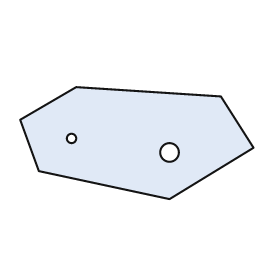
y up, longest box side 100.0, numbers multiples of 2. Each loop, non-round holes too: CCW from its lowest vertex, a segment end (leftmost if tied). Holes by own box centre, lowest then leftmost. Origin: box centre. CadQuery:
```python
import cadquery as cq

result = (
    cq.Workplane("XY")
    .moveTo(14.0, -24.0)
    .lineTo(50.0, -2.0)
    .lineTo(36.0, 20.0)
    .lineTo(-26.0, 24.0)
    .lineTo(-50.0, 10.0)
    .lineTo(-42.0, -12.0)
    .close()
    .moveTo(14.0, -4.0)
    .circle(4.0)
    .moveTo(-28.0, 2.0)
    .circle(2.0)
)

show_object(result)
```